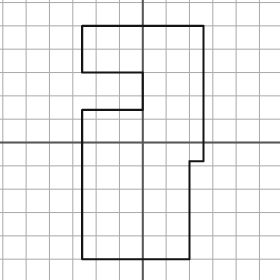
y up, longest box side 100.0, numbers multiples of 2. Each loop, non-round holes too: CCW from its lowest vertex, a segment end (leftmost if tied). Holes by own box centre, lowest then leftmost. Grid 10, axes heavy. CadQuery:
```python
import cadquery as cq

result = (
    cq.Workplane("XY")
    .moveTo(-26.0, -50.0)
    .lineTo(20.0, -50.0)
    .lineTo(20.0, -8.0)
    .lineTo(26.0, -8.0)
    .lineTo(26.0, 50.0)
    .lineTo(-26.0, 50.0)
    .lineTo(-26.0, 30.0)
    .lineTo(0.0, 30.0)
    .lineTo(0.0, 14.0)
    .lineTo(-26.0, 14.0)
    .close()
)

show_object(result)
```